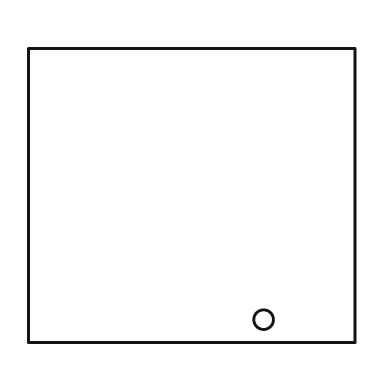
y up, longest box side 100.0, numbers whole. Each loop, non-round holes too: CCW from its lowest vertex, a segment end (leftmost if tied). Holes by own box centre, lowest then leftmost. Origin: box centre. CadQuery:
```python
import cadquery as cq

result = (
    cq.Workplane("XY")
    .moveTo(-50.0, -45.0)
    .lineTo(50.0, -45.0)
    .lineTo(50.0, 45.0)
    .lineTo(-50.0, 45.0)
    .close()
    .moveTo(22.0, -38.0)
    .circle(3.0)
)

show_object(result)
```